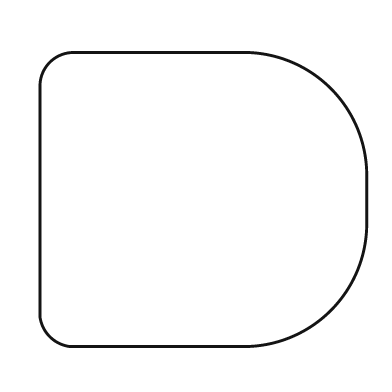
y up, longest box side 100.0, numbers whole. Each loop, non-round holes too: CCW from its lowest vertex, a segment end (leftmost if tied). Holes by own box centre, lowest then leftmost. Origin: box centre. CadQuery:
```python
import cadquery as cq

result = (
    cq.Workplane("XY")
    .moveTo(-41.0, -45.0)
    .lineTo(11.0, -45.0)
    .threePointArc((39.0, -34.0), (50.0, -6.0))
    .lineTo(50.0, 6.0)
    .threePointArc((39.0, 34.0), (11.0, 45.0))
    .lineTo(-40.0, 45.0)
    .threePointArc((-47.0, 42.0), (-50.0, 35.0))
    .lineTo(-50.0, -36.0)
    .threePointArc((-47.0, -42.0), (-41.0, -45.0))
    .close()
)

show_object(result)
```